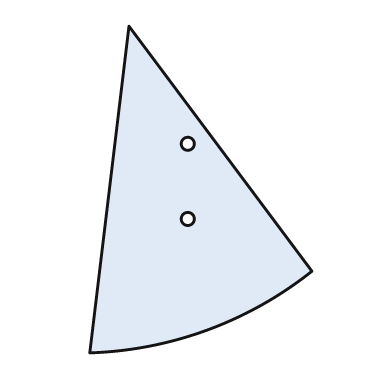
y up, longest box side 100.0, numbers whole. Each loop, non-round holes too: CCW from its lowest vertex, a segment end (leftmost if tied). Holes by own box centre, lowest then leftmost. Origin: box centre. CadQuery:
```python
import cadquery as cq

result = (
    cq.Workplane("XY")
    .moveTo(-34.0, -50.0)
    .threePointArc((2.0, -43.0), (34.0, -25.0))
    .lineTo(-22.0, 50.0)
    .close()
    .moveTo(-4.0, -9.0)
    .circle(2.0)
    .moveTo(-4.0, 14.0)
    .circle(2.0)
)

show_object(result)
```